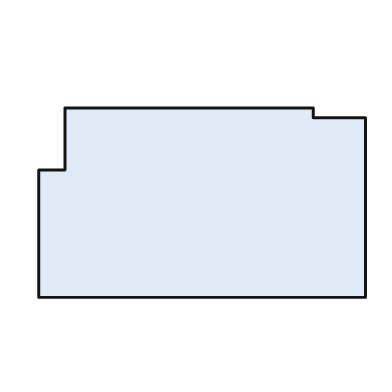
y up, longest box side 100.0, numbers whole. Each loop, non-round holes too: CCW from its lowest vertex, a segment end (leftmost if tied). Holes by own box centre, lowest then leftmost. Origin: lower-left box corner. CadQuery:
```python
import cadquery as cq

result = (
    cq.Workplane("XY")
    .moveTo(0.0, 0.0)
    .lineTo(100.0, 0.0)
    .lineTo(100.0, 55.0)
    .lineTo(84.0, 55.0)
    .lineTo(84.0, 58.0)
    .lineTo(8.0, 58.0)
    .lineTo(8.0, 39.0)
    .lineTo(0.0, 39.0)
    .close()
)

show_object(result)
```